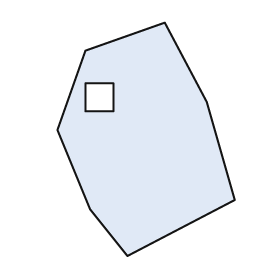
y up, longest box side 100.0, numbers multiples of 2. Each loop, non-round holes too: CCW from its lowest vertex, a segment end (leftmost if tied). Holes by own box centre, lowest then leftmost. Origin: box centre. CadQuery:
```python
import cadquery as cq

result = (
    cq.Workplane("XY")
    .moveTo(-8.0, -50.0)
    .lineTo(38.0, -26.0)
    .lineTo(26.0, 16.0)
    .lineTo(8.0, 50.0)
    .lineTo(-26.0, 38.0)
    .lineTo(-38.0, 4.0)
    .lineTo(-24.0, -30.0)
    .close()
    .moveTo(-26.0, 12.0)
    .lineTo(-14.0, 12.0)
    .lineTo(-14.0, 24.0)
    .lineTo(-26.0, 24.0)
    .close()
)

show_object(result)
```